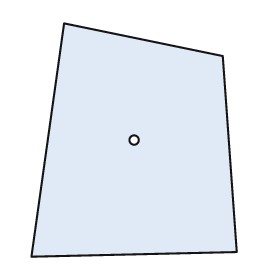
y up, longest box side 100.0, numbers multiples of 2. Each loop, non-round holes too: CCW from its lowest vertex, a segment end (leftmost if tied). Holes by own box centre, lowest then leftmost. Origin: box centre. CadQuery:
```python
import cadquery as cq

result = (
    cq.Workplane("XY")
    .moveTo(-44.0, -50.0)
    .lineTo(44.0, -48.0)
    .lineTo(38.0, 36.0)
    .lineTo(-30.0, 50.0)
    .close()
    .moveTo(0.0, 0.0)
    .circle(2.0)
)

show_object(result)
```